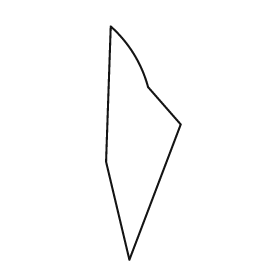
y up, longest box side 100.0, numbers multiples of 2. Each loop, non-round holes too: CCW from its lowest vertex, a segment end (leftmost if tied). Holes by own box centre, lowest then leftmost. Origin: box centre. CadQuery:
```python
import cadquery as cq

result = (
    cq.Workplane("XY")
    .moveTo(-6.0, -50.0)
    .lineTo(16.0, 8.0)
    .lineTo(2.0, 24.0)
    .threePointArc((-4.0, 38.0), (-14.0, 50.0))
    .lineTo(-16.0, -8.0)
    .close()
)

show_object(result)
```